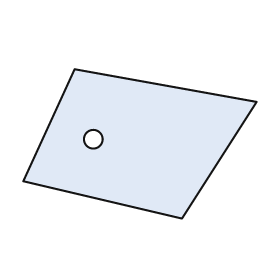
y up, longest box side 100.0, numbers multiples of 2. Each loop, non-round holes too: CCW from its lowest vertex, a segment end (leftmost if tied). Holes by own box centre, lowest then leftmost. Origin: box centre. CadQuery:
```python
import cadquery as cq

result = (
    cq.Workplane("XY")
    .moveTo(18.0, -32.0)
    .lineTo(50.0, 18.0)
    .lineTo(-28.0, 32.0)
    .lineTo(-50.0, -16.0)
    .close()
    .moveTo(-20.0, 2.0)
    .circle(4.0)
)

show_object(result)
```